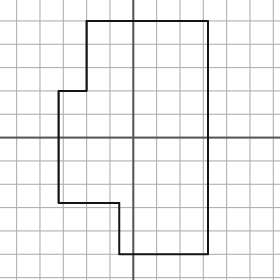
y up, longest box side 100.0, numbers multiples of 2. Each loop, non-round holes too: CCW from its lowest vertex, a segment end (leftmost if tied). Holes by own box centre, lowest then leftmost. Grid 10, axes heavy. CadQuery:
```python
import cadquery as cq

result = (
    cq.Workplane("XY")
    .moveTo(-6.0, -50.0)
    .lineTo(32.0, -50.0)
    .lineTo(32.0, 50.0)
    .lineTo(-20.0, 50.0)
    .lineTo(-20.0, 20.0)
    .lineTo(-32.0, 20.0)
    .lineTo(-32.0, -28.0)
    .lineTo(-6.0, -28.0)
    .close()
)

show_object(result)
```